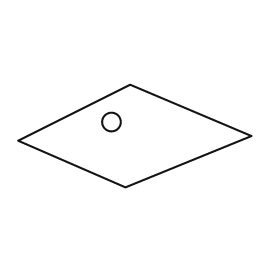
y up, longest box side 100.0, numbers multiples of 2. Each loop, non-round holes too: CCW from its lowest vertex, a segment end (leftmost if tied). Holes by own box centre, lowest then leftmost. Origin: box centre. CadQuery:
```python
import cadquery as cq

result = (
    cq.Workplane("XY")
    .moveTo(-4.0, -22.0)
    .lineTo(50.0, 0.0)
    .lineTo(-2.0, 22.0)
    .lineTo(-50.0, -2.0)
    .close()
    .moveTo(-10.0, 6.0)
    .circle(4.0)
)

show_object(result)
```